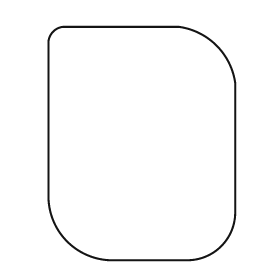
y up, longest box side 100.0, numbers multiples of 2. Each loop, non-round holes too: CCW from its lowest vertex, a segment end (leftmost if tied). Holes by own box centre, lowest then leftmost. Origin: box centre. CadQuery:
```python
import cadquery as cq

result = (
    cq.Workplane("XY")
    .moveTo(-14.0, -50.0)
    .lineTo(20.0, -50.0)
    .threePointArc((34.0, -44.0), (40.0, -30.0))
    .lineTo(40.0, 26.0)
    .threePointArc((32.0, 42.0), (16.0, 50.0))
    .lineTo(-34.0, 50.0)
    .threePointArc((-38.0, 48.0), (-40.0, 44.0))
    .lineTo(-40.0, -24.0)
    .threePointArc((-32.0, -42.0), (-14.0, -50.0))
    .close()
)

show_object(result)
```